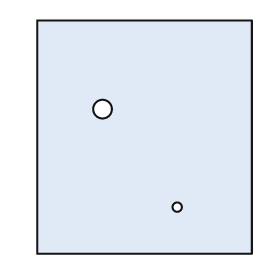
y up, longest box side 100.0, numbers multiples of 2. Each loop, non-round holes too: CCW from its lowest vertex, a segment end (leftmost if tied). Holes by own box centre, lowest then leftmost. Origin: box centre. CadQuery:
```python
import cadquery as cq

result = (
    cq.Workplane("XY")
    .moveTo(-46.0, -50.0)
    .lineTo(46.0, -50.0)
    .lineTo(46.0, 50.0)
    .lineTo(-46.0, 50.0)
    .close()
    .moveTo(14.0, -30.0)
    .circle(2.0)
    .moveTo(-18.0, 12.0)
    .circle(4.0)
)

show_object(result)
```